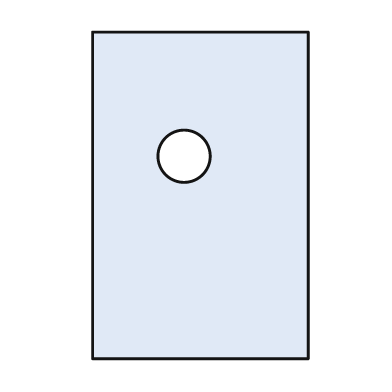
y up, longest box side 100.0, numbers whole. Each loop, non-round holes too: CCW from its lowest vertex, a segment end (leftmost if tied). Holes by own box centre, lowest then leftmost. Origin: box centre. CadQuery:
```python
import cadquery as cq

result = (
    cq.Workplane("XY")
    .moveTo(-33.0, -50.0)
    .lineTo(33.0, -50.0)
    .lineTo(33.0, 50.0)
    .lineTo(-33.0, 50.0)
    .close()
    .moveTo(-5.0, 12.0)
    .circle(8.0)
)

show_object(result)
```